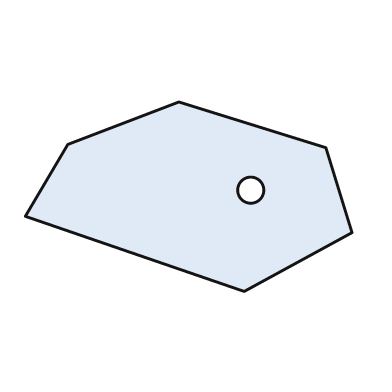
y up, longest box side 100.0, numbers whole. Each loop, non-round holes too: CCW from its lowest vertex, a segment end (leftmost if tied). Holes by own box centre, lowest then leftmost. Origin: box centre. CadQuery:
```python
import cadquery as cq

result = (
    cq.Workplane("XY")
    .moveTo(17.0, -29.0)
    .lineTo(50.0, -11.0)
    .lineTo(42.0, 15.0)
    .lineTo(-3.0, 29.0)
    .lineTo(-37.0, 16.0)
    .lineTo(-50.0, -6.0)
    .close()
    .moveTo(19.0, 2.0)
    .circle(4.0)
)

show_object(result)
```